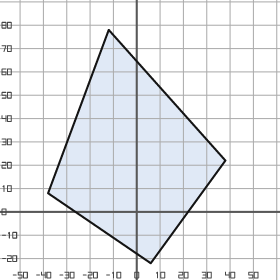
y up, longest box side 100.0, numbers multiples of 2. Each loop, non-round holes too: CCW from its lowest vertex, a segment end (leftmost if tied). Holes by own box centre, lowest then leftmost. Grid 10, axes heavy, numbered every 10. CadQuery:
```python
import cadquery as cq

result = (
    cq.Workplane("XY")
    .moveTo(6.0, -22.0)
    .lineTo(38.0, 22.0)
    .lineTo(-12.0, 78.0)
    .lineTo(-38.0, 8.0)
    .close()
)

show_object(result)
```